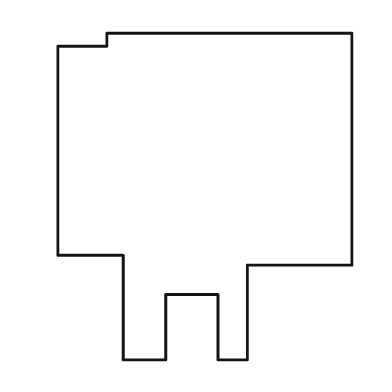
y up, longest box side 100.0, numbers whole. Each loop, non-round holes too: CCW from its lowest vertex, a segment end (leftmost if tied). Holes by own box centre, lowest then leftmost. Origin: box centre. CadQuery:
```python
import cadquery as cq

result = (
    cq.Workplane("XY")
    .moveTo(-25.0, -50.0)
    .lineTo(-12.0, -50.0)
    .lineTo(-12.0, -30.0)
    .lineTo(4.0, -30.0)
    .lineTo(4.0, -50.0)
    .lineTo(13.0, -50.0)
    .lineTo(13.0, -21.0)
    .lineTo(45.0, -21.0)
    .lineTo(45.0, 50.0)
    .lineTo(-30.0, 50.0)
    .lineTo(-30.0, 46.0)
    .lineTo(-45.0, 46.0)
    .lineTo(-45.0, -18.0)
    .lineTo(-25.0, -18.0)
    .close()
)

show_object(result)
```